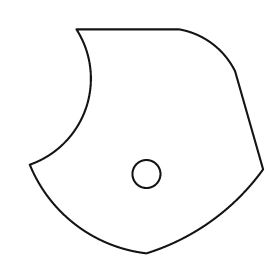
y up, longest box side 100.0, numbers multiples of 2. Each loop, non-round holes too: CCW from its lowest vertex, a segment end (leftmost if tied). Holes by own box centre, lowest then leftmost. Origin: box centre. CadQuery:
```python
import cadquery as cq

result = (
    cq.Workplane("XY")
    .moveTo(0.0, -48.0)
    .threePointArc((28.0, -34.0), (50.0, -12.0))
    .lineTo(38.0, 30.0)
    .threePointArc((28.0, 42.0), (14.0, 48.0))
    .lineTo(-30.0, 48.0)
    .threePointArc((-26.0, 14.0), (-50.0, -10.0))
    .threePointArc((-30.0, -36.0), (0.0, -48.0))
    .close()
    .moveTo(0.0, -14.0)
    .circle(6.0)
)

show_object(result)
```